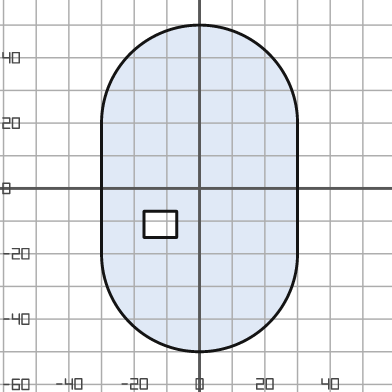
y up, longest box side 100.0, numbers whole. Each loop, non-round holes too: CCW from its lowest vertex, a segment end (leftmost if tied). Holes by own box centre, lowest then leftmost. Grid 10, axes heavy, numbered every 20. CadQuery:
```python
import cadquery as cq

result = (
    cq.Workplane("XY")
    .moveTo(-30.0, -20.0)
    .threePointArc((0.0, -50.0), (30.0, -20.0))
    .lineTo(30.0, 20.0)
    .threePointArc((0.0, 50.0), (-30.0, 20.0))
    .close()
    .moveTo(-17.0, -15.0)
    .lineTo(-7.0, -15.0)
    .lineTo(-7.0, -7.0)
    .lineTo(-17.0, -7.0)
    .close()
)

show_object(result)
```